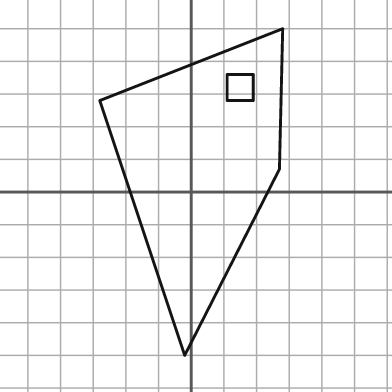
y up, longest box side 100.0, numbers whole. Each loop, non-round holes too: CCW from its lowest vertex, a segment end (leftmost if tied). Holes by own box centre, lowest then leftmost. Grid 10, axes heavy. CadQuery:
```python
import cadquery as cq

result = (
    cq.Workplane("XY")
    .moveTo(-2.0, -50.0)
    .lineTo(27.0, 7.0)
    .lineTo(28.0, 50.0)
    .lineTo(-28.0, 28.0)
    .close()
    .moveTo(11.0, 28.0)
    .lineTo(19.0, 28.0)
    .lineTo(19.0, 36.0)
    .lineTo(11.0, 36.0)
    .close()
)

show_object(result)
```